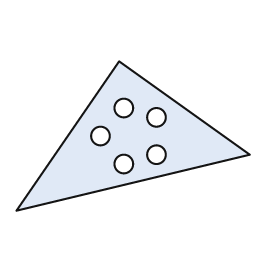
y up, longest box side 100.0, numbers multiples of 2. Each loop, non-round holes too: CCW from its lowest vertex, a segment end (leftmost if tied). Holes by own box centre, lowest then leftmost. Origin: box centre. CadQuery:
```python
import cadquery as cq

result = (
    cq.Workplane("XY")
    .moveTo(-50.0, -32.0)
    .lineTo(50.0, -8.0)
    .lineTo(-6.0, 32.0)
    .close()
    .moveTo(-4.0, -12.0)
    .circle(4.0)
    .moveTo(10.0, -8.0)
    .circle(4.0)
    .moveTo(-14.0, 0.0)
    .circle(4.0)
    .moveTo(10.0, 8.0)
    .circle(4.0)
    .moveTo(-4.0, 12.0)
    .circle(4.0)
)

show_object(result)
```